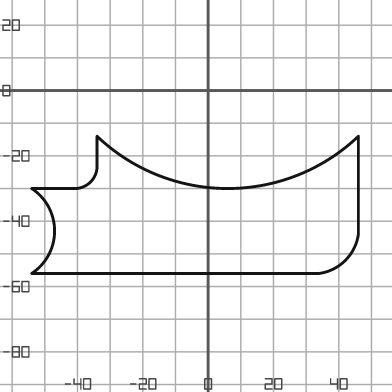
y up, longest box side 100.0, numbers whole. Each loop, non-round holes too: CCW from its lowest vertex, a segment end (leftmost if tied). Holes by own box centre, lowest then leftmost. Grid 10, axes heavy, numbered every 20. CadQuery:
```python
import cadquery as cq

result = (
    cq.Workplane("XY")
    .moveTo(-54.0, -56.0)
    .lineTo(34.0, -56.0)
    .threePointArc((42.0, -52.0), (46.0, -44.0))
    .lineTo(46.0, -14.0)
    .threePointArc((6.0, -30.0), (-34.0, -14.0))
    .lineTo(-34.0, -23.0)
    .threePointArc((-36.0, -28.0), (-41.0, -30.0))
    .lineTo(-54.0, -30.0)
    .threePointArc((-47.0, -43.0), (-54.0, -56.0))
    .close()
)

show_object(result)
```